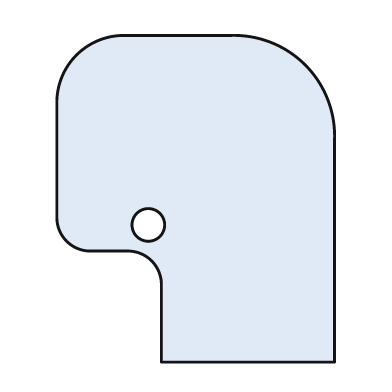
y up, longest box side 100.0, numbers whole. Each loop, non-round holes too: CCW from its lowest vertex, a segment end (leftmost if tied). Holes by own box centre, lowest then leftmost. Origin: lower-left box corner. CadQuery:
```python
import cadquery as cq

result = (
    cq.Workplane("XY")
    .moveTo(32.0, 0.0)
    .lineTo(85.0, 0.0)
    .lineTo(85.0, 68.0)
    .threePointArc((76.0, 91.0), (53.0, 100.0))
    .lineTo(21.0, 100.0)
    .threePointArc((6.0, 94.0), (0.0, 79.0))
    .lineTo(0.0, 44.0)
    .threePointArc((3.0, 37.0), (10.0, 34.0))
    .lineTo(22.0, 34.0)
    .threePointArc((29.0, 31.0), (32.0, 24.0))
    .close()
    .moveTo(28.0, 42.0)
    .circle(5.0)
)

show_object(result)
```